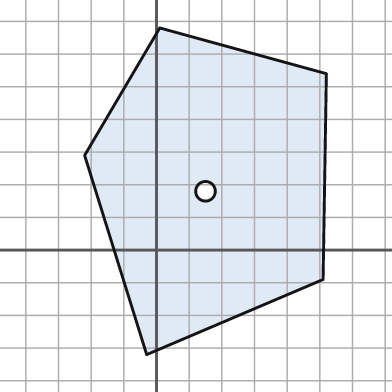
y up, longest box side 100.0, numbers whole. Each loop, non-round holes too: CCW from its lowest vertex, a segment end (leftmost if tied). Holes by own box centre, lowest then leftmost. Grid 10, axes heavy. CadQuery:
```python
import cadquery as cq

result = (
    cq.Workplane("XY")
    .moveTo(-3.0, -32.0)
    .lineTo(51.0, -9.0)
    .lineTo(52.0, 54.0)
    .lineTo(1.0, 68.0)
    .lineTo(-22.0, 29.0)
    .close()
    .moveTo(15.0, 18.0)
    .circle(3.0)
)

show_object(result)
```